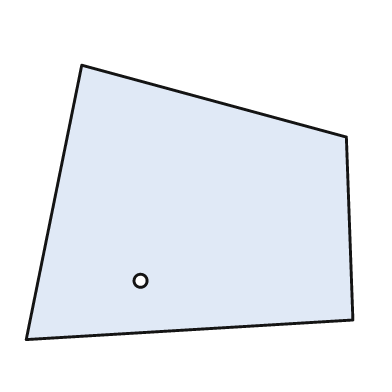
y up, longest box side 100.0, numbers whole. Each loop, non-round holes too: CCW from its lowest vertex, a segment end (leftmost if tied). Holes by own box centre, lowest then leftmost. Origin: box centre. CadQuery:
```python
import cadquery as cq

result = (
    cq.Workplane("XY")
    .moveTo(-50.0, -42.0)
    .lineTo(50.0, -36.0)
    .lineTo(48.0, 20.0)
    .lineTo(-33.0, 42.0)
    .close()
    .moveTo(-15.0, -24.0)
    .circle(2.0)
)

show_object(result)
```